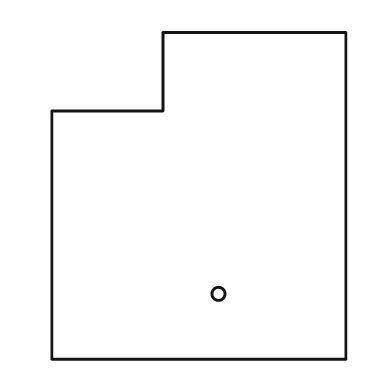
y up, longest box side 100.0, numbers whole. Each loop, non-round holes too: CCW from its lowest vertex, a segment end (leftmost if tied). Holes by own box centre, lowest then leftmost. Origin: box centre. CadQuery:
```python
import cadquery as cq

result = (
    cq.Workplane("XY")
    .moveTo(-45.0, -50.0)
    .lineTo(45.0, -50.0)
    .lineTo(45.0, 50.0)
    .lineTo(-11.0, 50.0)
    .lineTo(-11.0, 26.0)
    .lineTo(-45.0, 26.0)
    .close()
    .moveTo(6.0, -30.0)
    .circle(2.0)
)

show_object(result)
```